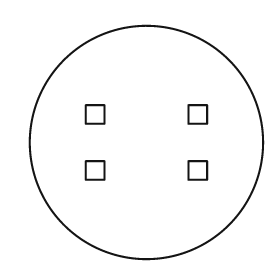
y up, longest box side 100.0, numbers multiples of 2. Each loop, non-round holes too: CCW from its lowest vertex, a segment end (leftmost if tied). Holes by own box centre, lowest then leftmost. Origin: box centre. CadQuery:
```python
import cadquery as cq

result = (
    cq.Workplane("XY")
    .moveTo(0.0, 0.0)
    .circle(50.0)
    .moveTo(-26.0, -16.0)
    .lineTo(-18.0, -16.0)
    .lineTo(-18.0, -8.0)
    .lineTo(-26.0, -8.0)
    .close()
    .moveTo(18.0, -16.0)
    .lineTo(26.0, -16.0)
    .lineTo(26.0, -8.0)
    .lineTo(18.0, -8.0)
    .close()
    .moveTo(-26.0, 8.0)
    .lineTo(-18.0, 8.0)
    .lineTo(-18.0, 16.0)
    .lineTo(-26.0, 16.0)
    .close()
    .moveTo(18.0, 8.0)
    .lineTo(26.0, 8.0)
    .lineTo(26.0, 16.0)
    .lineTo(18.0, 16.0)
    .close()
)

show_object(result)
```